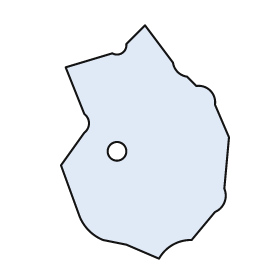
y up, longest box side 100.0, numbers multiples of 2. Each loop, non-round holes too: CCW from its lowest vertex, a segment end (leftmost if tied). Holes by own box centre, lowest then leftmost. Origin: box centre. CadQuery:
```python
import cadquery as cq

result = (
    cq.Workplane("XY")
    .moveTo(6.0, -50.0)
    .threePointArc((12.0, -44.0), (20.0, -42.0))
    .lineTo(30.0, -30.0)
    .threePointArc((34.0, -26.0), (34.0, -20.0))
    .lineTo(36.0, 2.0)
    .lineTo(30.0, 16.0)
    .threePointArc((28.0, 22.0), (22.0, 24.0))
    .lineTo(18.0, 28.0)
    .threePointArc((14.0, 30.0), (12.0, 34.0))
    .lineTo(0.0, 50.0)
    .lineTo(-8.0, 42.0)
    .threePointArc((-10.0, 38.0), (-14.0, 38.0))
    .lineTo(-34.0, 32.0)
    .lineTo(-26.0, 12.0)
    .threePointArc((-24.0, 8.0), (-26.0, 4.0))
    .lineTo(-36.0, -10.0)
    .lineTo(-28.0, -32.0)
    .threePointArc((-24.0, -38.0), (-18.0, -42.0))
    .lineTo(-8.0, -44.0)
    .close()
    .moveTo(-12.0, -4.0)
    .circle(4.0)
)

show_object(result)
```